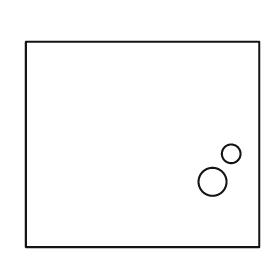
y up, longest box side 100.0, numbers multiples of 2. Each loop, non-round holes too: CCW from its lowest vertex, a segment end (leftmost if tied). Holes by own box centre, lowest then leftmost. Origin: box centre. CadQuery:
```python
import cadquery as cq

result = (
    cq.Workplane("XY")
    .moveTo(-50.0, -44.0)
    .lineTo(50.0, -44.0)
    .lineTo(50.0, 44.0)
    .lineTo(-50.0, 44.0)
    .close()
    .moveTo(30.0, -16.0)
    .circle(6.0)
    .moveTo(38.0, -4.0)
    .circle(4.0)
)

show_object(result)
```